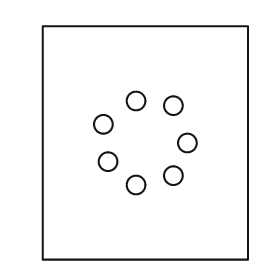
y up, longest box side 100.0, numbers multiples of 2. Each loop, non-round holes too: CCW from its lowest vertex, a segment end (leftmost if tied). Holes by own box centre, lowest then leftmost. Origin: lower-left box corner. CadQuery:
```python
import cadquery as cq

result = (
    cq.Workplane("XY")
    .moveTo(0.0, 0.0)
    .lineTo(88.0, 0.0)
    .lineTo(88.0, 100.0)
    .lineTo(0.0, 100.0)
    .close()
    .moveTo(40.0, 32.0)
    .circle(4.0)
    .moveTo(56.0, 36.0)
    .circle(4.0)
    .moveTo(28.0, 42.0)
    .circle(4.0)
    .moveTo(62.0, 50.0)
    .circle(4.0)
    .moveTo(26.0, 58.0)
    .circle(4.0)
    .moveTo(56.0, 66.0)
    .circle(4.0)
    .moveTo(40.0, 68.0)
    .circle(4.0)
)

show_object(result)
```